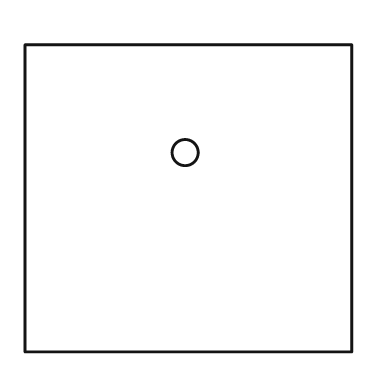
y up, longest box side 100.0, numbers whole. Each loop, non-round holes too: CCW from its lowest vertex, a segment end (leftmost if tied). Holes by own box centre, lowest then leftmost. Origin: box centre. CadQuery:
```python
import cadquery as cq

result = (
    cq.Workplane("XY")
    .moveTo(-50.0, -47.0)
    .lineTo(50.0, -47.0)
    .lineTo(50.0, 47.0)
    .lineTo(-50.0, 47.0)
    .close()
    .moveTo(-1.0, 14.0)
    .circle(4.0)
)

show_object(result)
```